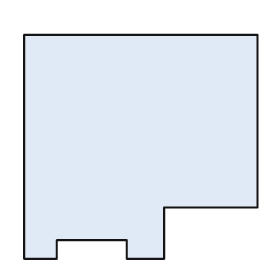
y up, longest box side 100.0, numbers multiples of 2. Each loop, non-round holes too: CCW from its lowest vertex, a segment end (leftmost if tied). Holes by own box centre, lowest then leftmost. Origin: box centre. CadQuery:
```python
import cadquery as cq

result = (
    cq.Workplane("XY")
    .moveTo(-50.0, -48.0)
    .lineTo(-36.0, -48.0)
    .lineTo(-36.0, -40.0)
    .lineTo(-6.0, -40.0)
    .lineTo(-6.0, -48.0)
    .lineTo(10.0, -48.0)
    .lineTo(10.0, -26.0)
    .lineTo(50.0, -26.0)
    .lineTo(50.0, 48.0)
    .lineTo(-50.0, 48.0)
    .close()
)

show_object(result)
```